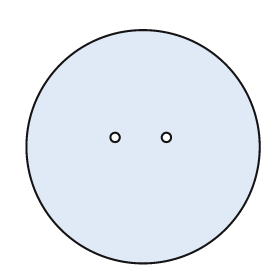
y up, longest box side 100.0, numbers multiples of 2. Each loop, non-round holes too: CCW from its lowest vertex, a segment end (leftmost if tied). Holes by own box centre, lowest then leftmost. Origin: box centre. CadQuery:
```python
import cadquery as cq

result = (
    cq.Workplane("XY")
    .moveTo(0.0, 0.0)
    .circle(50.0)
    .moveTo(-12.0, 4.0)
    .circle(2.0)
    .moveTo(10.0, 4.0)
    .circle(2.0)
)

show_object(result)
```